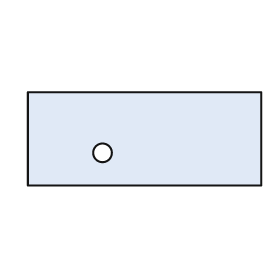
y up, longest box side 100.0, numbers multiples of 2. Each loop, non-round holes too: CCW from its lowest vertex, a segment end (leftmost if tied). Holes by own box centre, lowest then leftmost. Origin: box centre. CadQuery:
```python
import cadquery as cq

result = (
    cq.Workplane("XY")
    .moveTo(-50.0, -20.0)
    .lineTo(50.0, -20.0)
    .lineTo(50.0, 20.0)
    .lineTo(-50.0, 20.0)
    .close()
    .moveTo(-18.0, -6.0)
    .circle(4.0)
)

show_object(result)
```